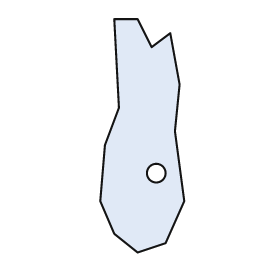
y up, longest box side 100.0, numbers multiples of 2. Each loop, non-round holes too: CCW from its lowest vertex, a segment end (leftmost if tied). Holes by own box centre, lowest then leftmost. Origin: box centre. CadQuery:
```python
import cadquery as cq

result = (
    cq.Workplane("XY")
    .moveTo(-2.0, -50.0)
    .lineTo(10.0, -46.0)
    .lineTo(18.0, -28.0)
    .lineTo(14.0, 2.0)
    .lineTo(16.0, 22.0)
    .lineTo(12.0, 44.0)
    .lineTo(4.0, 38.0)
    .lineTo(-2.0, 50.0)
    .lineTo(-12.0, 50.0)
    .lineTo(-10.0, 12.0)
    .lineTo(-16.0, -4.0)
    .lineTo(-18.0, -28.0)
    .lineTo(-12.0, -42.0)
    .close()
    .moveTo(6.0, -16.0)
    .circle(4.0)
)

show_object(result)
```